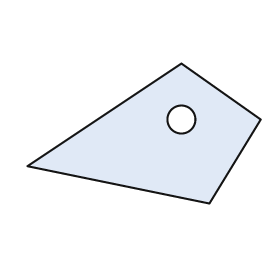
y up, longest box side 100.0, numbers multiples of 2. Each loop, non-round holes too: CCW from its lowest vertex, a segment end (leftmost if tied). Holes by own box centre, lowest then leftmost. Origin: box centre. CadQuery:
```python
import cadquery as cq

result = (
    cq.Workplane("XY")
    .moveTo(28.0, -30.0)
    .lineTo(50.0, 6.0)
    .lineTo(16.0, 30.0)
    .lineTo(-50.0, -14.0)
    .close()
    .moveTo(16.0, 6.0)
    .circle(6.0)
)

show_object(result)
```